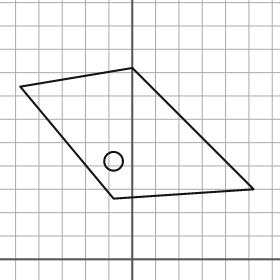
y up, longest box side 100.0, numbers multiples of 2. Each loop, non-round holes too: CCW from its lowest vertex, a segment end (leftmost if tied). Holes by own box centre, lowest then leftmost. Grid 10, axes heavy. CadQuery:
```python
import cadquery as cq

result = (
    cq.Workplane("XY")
    .moveTo(-8.0, 26.0)
    .lineTo(52.0, 30.0)
    .lineTo(0.0, 82.0)
    .lineTo(-48.0, 74.0)
    .close()
    .moveTo(-8.0, 42.0)
    .circle(4.0)
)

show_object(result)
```